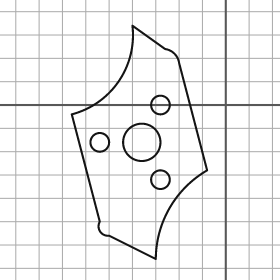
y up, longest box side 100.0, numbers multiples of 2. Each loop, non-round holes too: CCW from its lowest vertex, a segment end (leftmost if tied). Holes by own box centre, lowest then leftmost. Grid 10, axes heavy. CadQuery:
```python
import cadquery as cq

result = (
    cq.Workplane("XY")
    .moveTo(-30.0, -66.0)
    .threePointArc((-24.0, -44.0), (-8.0, -28.0))
    .lineTo(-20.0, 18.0)
    .threePointArc((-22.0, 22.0), (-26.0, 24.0))
    .lineTo(-40.0, 34.0)
    .threePointArc((-46.0, 10.0), (-66.0, -4.0))
    .lineTo(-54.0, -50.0)
    .threePointArc((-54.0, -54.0), (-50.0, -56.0))
    .close()
    .moveTo(-28.0, -32.0)
    .circle(4.0)
    .moveTo(-54.0, -16.0)
    .circle(4.0)
    .moveTo(-36.0, -16.0)
    .circle(8.0)
    .moveTo(-28.0, 0.0)
    .circle(4.0)
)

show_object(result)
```